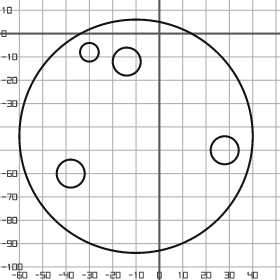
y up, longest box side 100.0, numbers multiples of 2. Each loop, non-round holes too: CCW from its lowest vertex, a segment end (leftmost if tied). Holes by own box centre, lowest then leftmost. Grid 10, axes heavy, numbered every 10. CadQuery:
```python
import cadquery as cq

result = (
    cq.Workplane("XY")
    .moveTo(-10.0, -44.0)
    .circle(50.0)
    .moveTo(-38.0, -60.0)
    .circle(6.0)
    .moveTo(28.0, -50.0)
    .circle(6.0)
    .moveTo(-14.0, -12.0)
    .circle(6.0)
    .moveTo(-30.0, -8.0)
    .circle(4.0)
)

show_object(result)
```